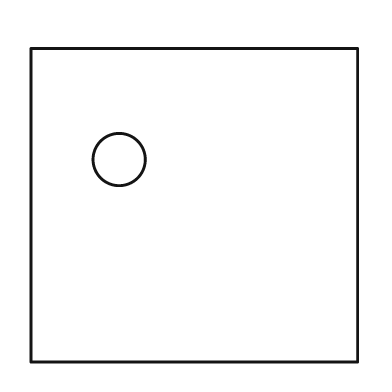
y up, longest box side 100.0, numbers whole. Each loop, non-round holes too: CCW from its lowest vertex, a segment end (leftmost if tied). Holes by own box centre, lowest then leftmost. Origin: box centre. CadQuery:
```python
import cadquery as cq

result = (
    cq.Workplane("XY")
    .moveTo(-50.0, -48.0)
    .lineTo(50.0, -48.0)
    .lineTo(50.0, 48.0)
    .lineTo(-50.0, 48.0)
    .close()
    .moveTo(-23.0, 14.0)
    .circle(8.0)
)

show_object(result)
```